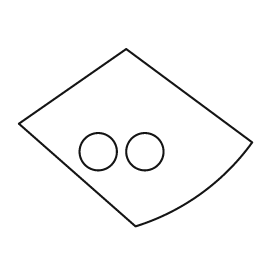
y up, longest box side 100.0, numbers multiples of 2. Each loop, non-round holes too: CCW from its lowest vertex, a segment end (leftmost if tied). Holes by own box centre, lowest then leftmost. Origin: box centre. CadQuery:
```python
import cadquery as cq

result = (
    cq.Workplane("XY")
    .moveTo(0.0, -38.0)
    .threePointArc((28.0, -24.0), (50.0, -2.0))
    .lineTo(-4.0, 38.0)
    .lineTo(-50.0, 6.0)
    .close()
    .moveTo(-16.0, -6.0)
    .circle(8.0)
    .moveTo(4.0, -6.0)
    .circle(8.0)
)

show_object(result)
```